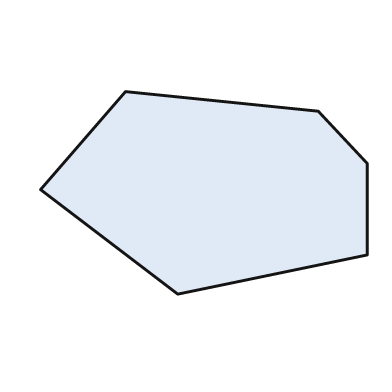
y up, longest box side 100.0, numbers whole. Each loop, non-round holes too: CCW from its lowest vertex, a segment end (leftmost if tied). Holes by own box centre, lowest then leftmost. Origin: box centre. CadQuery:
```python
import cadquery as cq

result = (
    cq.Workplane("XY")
    .moveTo(-8.0, -31.0)
    .lineTo(50.0, -19.0)
    .lineTo(50.0, 9.0)
    .lineTo(35.0, 25.0)
    .lineTo(-24.0, 31.0)
    .lineTo(-50.0, 1.0)
    .close()
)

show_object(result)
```